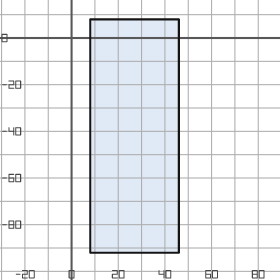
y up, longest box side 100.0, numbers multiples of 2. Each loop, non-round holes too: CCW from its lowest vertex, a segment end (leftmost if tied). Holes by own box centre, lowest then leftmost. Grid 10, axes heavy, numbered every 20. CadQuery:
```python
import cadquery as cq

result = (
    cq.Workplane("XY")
    .moveTo(8.0, -92.0)
    .lineTo(46.0, -92.0)
    .lineTo(46.0, 8.0)
    .lineTo(8.0, 8.0)
    .close()
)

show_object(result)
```